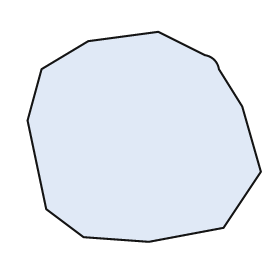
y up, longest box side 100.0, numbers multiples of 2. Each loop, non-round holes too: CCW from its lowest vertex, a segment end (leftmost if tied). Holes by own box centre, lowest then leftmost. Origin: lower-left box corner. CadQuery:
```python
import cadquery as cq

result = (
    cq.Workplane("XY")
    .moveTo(52.0, 0.0)
    .lineTo(84.0, 6.0)
    .lineTo(100.0, 30.0)
    .lineTo(92.0, 58.0)
    .lineTo(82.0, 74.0)
    .threePointArc((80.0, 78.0), (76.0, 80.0))
    .lineTo(56.0, 90.0)
    .lineTo(26.0, 86.0)
    .lineTo(6.0, 74.0)
    .lineTo(0.0, 52.0)
    .lineTo(8.0, 14.0)
    .lineTo(24.0, 2.0)
    .close()
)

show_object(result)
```